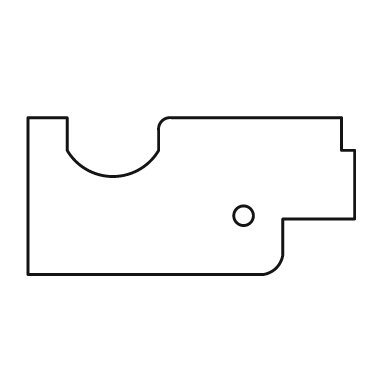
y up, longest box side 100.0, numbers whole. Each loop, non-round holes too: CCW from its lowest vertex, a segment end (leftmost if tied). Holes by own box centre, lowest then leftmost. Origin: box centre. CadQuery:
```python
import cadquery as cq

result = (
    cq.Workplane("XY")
    .moveTo(-50.0, -24.0)
    .lineTo(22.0, -24.0)
    .threePointArc((26.0, -22.0), (28.0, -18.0))
    .lineTo(28.0, -7.0)
    .lineTo(50.0, -7.0)
    .lineTo(50.0, 14.0)
    .lineTo(46.0, 14.0)
    .lineTo(46.0, 24.0)
    .lineTo(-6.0, 24.0)
    .threePointArc((-9.0, 23.0), (-10.0, 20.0))
    .lineTo(-10.0, 14.0)
    .threePointArc((-24.0, 6.0), (-38.0, 14.0))
    .lineTo(-38.0, 24.0)
    .lineTo(-50.0, 24.0)
    .close()
    .moveTo(16.0, -6.0)
    .circle(3.0)
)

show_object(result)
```